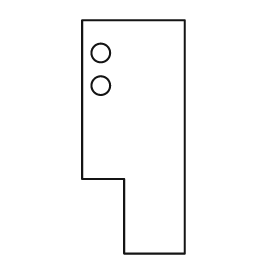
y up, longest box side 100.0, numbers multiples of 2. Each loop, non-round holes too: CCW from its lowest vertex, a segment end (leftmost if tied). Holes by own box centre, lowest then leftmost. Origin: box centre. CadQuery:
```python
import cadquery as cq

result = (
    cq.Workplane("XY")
    .moveTo(-4.0, -50.0)
    .lineTo(22.0, -50.0)
    .lineTo(22.0, 50.0)
    .lineTo(-22.0, 50.0)
    .lineTo(-22.0, -18.0)
    .lineTo(-4.0, -18.0)
    .close()
    .moveTo(-14.0, 22.0)
    .circle(4.0)
    .moveTo(-14.0, 36.0)
    .circle(4.0)
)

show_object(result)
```